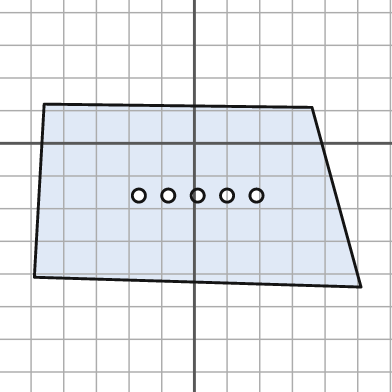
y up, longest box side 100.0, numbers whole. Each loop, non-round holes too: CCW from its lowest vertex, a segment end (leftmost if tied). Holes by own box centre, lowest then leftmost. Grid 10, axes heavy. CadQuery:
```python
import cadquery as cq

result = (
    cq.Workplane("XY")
    .moveTo(51.0, -44.0)
    .lineTo(36.0, 11.0)
    .lineTo(-46.0, 12.0)
    .lineTo(-49.0, -41.0)
    .close()
    .moveTo(-17.0, -16.0)
    .circle(2.0)
    .moveTo(-8.0, -16.0)
    .circle(2.0)
    .moveTo(1.0, -16.0)
    .circle(2.0)
    .moveTo(10.0, -16.0)
    .circle(2.0)
    .moveTo(19.0, -16.0)
    .circle(2.0)
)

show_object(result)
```